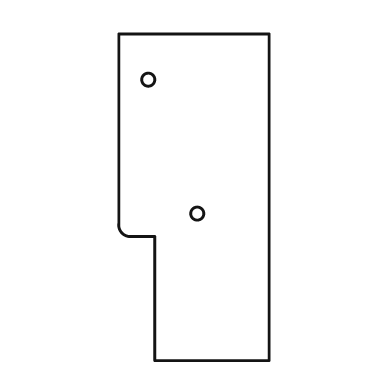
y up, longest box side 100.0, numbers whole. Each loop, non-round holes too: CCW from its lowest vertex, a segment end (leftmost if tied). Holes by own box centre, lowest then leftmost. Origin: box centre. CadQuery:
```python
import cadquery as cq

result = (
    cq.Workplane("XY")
    .moveTo(-12.0, -50.0)
    .lineTo(23.0, -50.0)
    .lineTo(23.0, 50.0)
    .lineTo(-23.0, 50.0)
    .lineTo(-23.0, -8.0)
    .threePointArc((-22.0, -11.0), (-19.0, -12.0))
    .lineTo(-12.0, -12.0)
    .close()
    .moveTo(1.0, -5.0)
    .circle(2.0)
    .moveTo(-14.0, 36.0)
    .circle(2.0)
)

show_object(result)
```